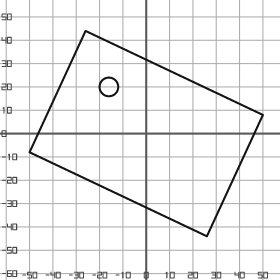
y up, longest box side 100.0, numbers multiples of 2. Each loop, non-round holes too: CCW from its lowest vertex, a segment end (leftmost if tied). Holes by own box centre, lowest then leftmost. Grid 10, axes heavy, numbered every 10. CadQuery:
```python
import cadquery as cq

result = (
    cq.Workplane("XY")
    .moveTo(26.0, -44.0)
    .lineTo(50.0, 8.0)
    .lineTo(-26.0, 44.0)
    .lineTo(-50.0, -8.0)
    .close()
    .moveTo(-16.0, 20.0)
    .circle(4.0)
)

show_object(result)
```